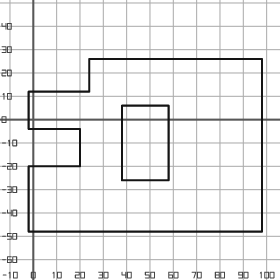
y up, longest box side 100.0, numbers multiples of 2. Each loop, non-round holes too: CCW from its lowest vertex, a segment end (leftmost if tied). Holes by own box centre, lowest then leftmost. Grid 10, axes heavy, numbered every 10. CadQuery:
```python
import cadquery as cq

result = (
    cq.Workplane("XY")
    .moveTo(-2.0, -48.0)
    .lineTo(98.0, -48.0)
    .lineTo(98.0, 26.0)
    .lineTo(24.0, 26.0)
    .lineTo(24.0, 12.0)
    .lineTo(-2.0, 12.0)
    .lineTo(-2.0, -4.0)
    .lineTo(20.0, -4.0)
    .lineTo(20.0, -20.0)
    .lineTo(-2.0, -20.0)
    .close()
    .moveTo(38.0, -26.0)
    .lineTo(58.0, -26.0)
    .lineTo(58.0, 6.0)
    .lineTo(38.0, 6.0)
    .close()
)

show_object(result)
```